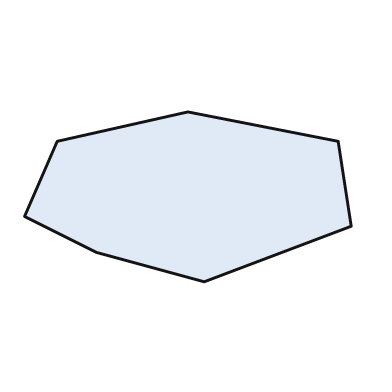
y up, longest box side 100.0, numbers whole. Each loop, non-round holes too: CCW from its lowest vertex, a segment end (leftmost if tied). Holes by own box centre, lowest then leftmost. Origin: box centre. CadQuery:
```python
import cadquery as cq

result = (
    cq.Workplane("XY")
    .moveTo(5.0, -26.0)
    .lineTo(50.0, -9.0)
    .lineTo(46.0, 17.0)
    .lineTo(0.0, 26.0)
    .lineTo(-40.0, 17.0)
    .lineTo(-50.0, -6.0)
    .lineTo(-28.0, -17.0)
    .close()
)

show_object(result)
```